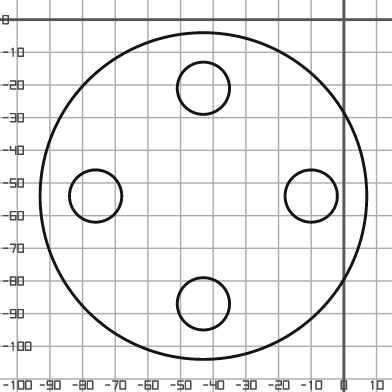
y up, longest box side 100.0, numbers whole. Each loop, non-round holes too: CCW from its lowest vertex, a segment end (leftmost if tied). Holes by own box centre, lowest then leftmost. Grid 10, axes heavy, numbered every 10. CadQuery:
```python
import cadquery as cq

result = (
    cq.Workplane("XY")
    .moveTo(-43.0, -54.0)
    .circle(50.0)
    .moveTo(-43.0, -87.0)
    .circle(8.0)
    .moveTo(-76.0, -54.0)
    .circle(8.0)
    .moveTo(-10.0, -54.0)
    .circle(8.0)
    .moveTo(-43.0, -21.0)
    .circle(8.0)
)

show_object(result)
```